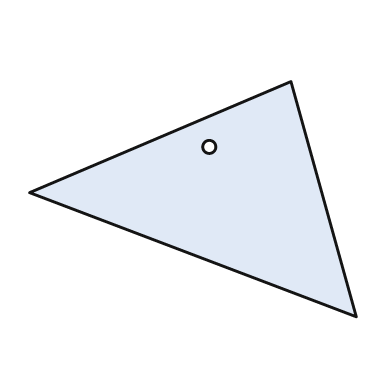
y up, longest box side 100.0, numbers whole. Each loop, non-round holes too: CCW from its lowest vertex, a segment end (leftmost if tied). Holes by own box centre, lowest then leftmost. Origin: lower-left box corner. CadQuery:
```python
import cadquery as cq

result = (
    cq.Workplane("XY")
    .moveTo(100.0, 0.0)
    .lineTo(80.0, 72.0)
    .lineTo(0.0, 38.0)
    .close()
    .moveTo(55.0, 52.0)
    .circle(2.0)
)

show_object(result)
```